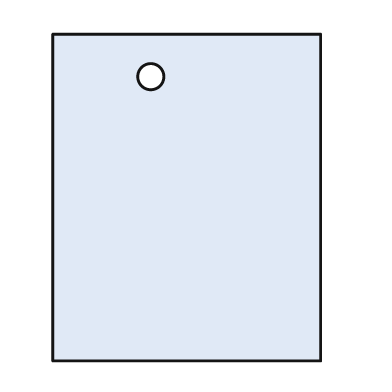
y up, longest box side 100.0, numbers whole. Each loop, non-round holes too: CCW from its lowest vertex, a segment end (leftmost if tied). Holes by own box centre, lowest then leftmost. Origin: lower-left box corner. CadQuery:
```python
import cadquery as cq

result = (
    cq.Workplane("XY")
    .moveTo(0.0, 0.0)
    .lineTo(82.0, 0.0)
    .lineTo(82.0, 100.0)
    .lineTo(0.0, 100.0)
    .close()
    .moveTo(30.0, 87.0)
    .circle(4.0)
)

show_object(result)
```